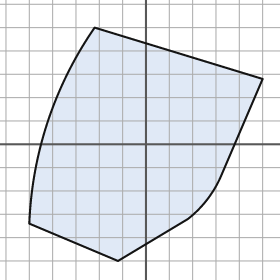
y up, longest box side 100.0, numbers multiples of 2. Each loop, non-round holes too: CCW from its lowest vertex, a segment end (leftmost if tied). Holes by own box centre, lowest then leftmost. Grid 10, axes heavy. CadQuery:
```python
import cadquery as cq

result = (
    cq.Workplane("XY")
    .moveTo(-12.0, -50.0)
    .lineTo(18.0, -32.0)
    .threePointArc((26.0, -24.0), (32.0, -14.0))
    .lineTo(50.0, 28.0)
    .lineTo(-22.0, 50.0)
    .threePointArc((-42.0, 10.0), (-50.0, -34.0))
    .close()
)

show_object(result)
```